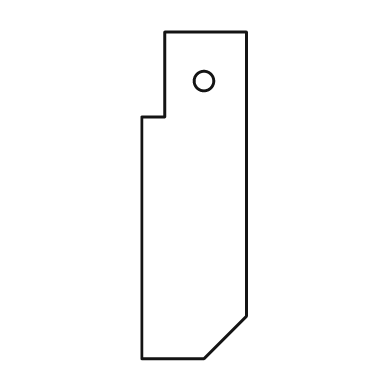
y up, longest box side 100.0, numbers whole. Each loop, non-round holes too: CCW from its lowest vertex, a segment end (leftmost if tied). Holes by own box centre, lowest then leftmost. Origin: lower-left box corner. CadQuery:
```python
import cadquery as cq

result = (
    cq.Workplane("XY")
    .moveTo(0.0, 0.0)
    .lineTo(19.0, 0.0)
    .lineTo(32.0, 13.0)
    .lineTo(32.0, 100.0)
    .lineTo(7.0, 100.0)
    .lineTo(7.0, 74.0)
    .lineTo(0.0, 74.0)
    .close()
    .moveTo(19.0, 85.0)
    .circle(3.0)
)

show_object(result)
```